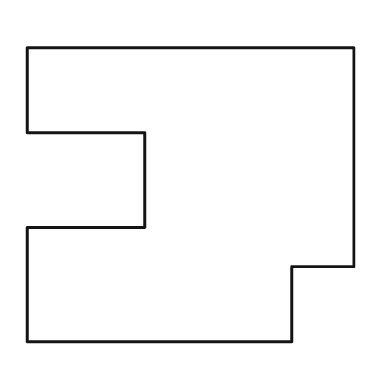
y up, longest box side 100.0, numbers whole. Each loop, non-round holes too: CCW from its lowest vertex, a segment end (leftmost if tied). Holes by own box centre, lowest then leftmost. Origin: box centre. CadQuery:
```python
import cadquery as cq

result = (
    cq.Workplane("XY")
    .moveTo(-50.0, -45.0)
    .lineTo(31.0, -45.0)
    .lineTo(31.0, -22.0)
    .lineTo(50.0, -22.0)
    .lineTo(50.0, 45.0)
    .lineTo(-50.0, 45.0)
    .lineTo(-50.0, 19.0)
    .lineTo(-14.0, 19.0)
    .lineTo(-14.0, -10.0)
    .lineTo(-50.0, -10.0)
    .close()
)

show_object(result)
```